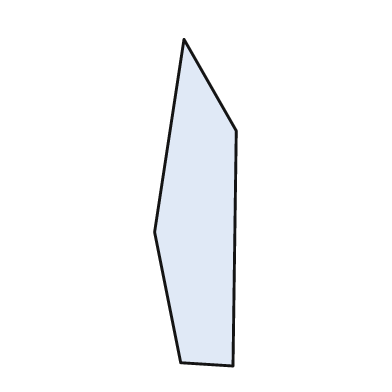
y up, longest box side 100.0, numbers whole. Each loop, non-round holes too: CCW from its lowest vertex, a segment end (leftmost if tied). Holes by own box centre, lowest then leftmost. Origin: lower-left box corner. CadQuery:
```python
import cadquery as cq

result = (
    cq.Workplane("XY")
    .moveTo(24.0, 0.0)
    .lineTo(25.0, 72.0)
    .lineTo(9.0, 100.0)
    .lineTo(0.0, 41.0)
    .lineTo(8.0, 1.0)
    .close()
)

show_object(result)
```